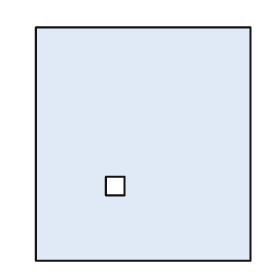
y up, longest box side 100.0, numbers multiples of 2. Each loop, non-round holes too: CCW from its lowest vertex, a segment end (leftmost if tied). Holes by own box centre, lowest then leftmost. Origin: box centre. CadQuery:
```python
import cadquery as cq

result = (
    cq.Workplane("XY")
    .moveTo(-46.0, -50.0)
    .lineTo(46.0, -50.0)
    .lineTo(46.0, 50.0)
    .lineTo(-46.0, 50.0)
    .close()
    .moveTo(-16.0, -22.0)
    .lineTo(-8.0, -22.0)
    .lineTo(-8.0, -14.0)
    .lineTo(-16.0, -14.0)
    .close()
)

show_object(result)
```